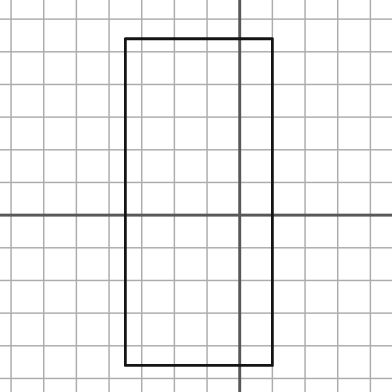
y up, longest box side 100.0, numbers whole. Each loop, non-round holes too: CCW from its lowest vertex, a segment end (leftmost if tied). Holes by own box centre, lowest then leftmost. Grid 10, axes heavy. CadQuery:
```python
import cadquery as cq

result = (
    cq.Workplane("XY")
    .moveTo(-35.0, -46.0)
    .lineTo(10.0, -46.0)
    .lineTo(10.0, 54.0)
    .lineTo(-35.0, 54.0)
    .close()
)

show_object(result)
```